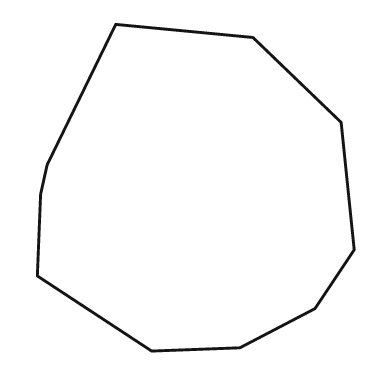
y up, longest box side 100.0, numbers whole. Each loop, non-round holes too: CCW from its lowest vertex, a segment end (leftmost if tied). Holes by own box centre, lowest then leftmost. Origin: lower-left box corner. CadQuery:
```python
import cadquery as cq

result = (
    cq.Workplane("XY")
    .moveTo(35.0, 0.0)
    .lineTo(62.0, 1.0)
    .lineTo(85.0, 13.0)
    .lineTo(97.0, 31.0)
    .lineTo(93.0, 70.0)
    .lineTo(66.0, 96.0)
    .lineTo(24.0, 100.0)
    .lineTo(3.0, 57.0)
    .lineTo(1.0, 48.0)
    .lineTo(0.0, 23.0)
    .close()
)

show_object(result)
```